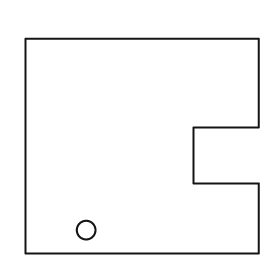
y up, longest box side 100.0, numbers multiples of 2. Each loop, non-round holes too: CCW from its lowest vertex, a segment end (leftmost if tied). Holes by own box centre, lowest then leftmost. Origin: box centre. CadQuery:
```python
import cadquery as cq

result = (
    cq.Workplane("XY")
    .moveTo(-50.0, -46.0)
    .lineTo(50.0, -46.0)
    .lineTo(50.0, -16.0)
    .lineTo(22.0, -16.0)
    .lineTo(22.0, 8.0)
    .lineTo(50.0, 8.0)
    .lineTo(50.0, 46.0)
    .lineTo(-50.0, 46.0)
    .close()
    .moveTo(-24.0, -36.0)
    .circle(4.0)
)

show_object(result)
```